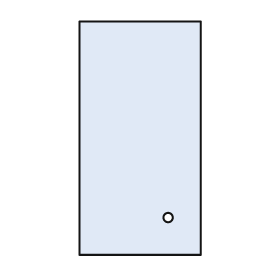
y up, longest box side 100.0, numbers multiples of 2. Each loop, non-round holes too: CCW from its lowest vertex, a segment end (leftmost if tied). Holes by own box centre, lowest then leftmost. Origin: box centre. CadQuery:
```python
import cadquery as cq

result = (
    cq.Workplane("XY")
    .moveTo(-26.0, -50.0)
    .lineTo(26.0, -50.0)
    .lineTo(26.0, 50.0)
    .lineTo(-26.0, 50.0)
    .close()
    .moveTo(12.0, -34.0)
    .circle(2.0)
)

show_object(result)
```